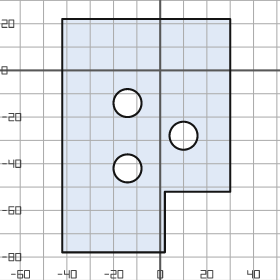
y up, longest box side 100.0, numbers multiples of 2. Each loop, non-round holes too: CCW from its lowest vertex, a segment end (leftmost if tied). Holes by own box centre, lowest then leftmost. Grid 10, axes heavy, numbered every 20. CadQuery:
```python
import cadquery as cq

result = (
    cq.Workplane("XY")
    .moveTo(-42.0, -78.0)
    .lineTo(2.0, -78.0)
    .lineTo(2.0, -52.0)
    .lineTo(30.0, -52.0)
    .lineTo(30.0, 22.0)
    .lineTo(-42.0, 22.0)
    .close()
    .moveTo(-14.0, -42.0)
    .circle(6.0)
    .moveTo(10.0, -28.0)
    .circle(6.0)
    .moveTo(-14.0, -14.0)
    .circle(6.0)
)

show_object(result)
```